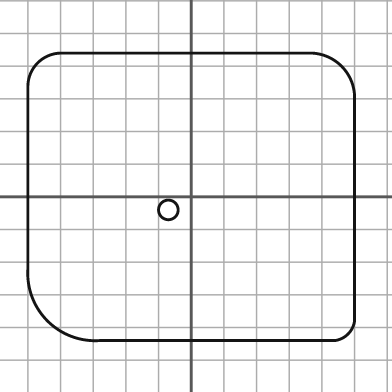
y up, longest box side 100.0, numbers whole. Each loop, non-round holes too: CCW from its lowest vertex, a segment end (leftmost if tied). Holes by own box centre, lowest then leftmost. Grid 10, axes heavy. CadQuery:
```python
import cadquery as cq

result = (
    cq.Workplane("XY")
    .moveTo(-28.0, -44.0)
    .lineTo(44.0, -44.0)
    .threePointArc((48.0, -42.0), (50.0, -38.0))
    .lineTo(50.0, 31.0)
    .threePointArc((46.0, 40.0), (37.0, 44.0))
    .lineTo(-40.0, 44.0)
    .threePointArc((-47.0, 41.0), (-50.0, 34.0))
    .lineTo(-50.0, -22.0)
    .threePointArc((-44.0, -38.0), (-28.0, -44.0))
    .close()
    .moveTo(-7.0, -4.0)
    .circle(3.0)
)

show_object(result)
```